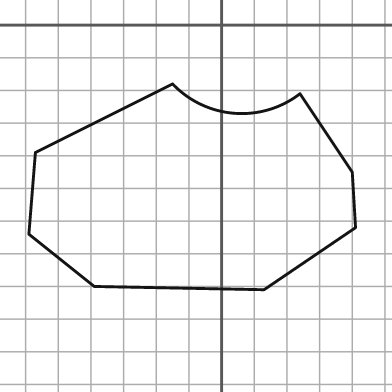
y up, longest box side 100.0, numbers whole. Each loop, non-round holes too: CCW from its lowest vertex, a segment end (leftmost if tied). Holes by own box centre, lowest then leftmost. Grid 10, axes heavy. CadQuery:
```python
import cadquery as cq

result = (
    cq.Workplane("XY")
    .moveTo(13.0, -81.0)
    .lineTo(41.0, -62.0)
    .lineTo(40.0, -45.0)
    .lineTo(24.0, -21.0)
    .threePointArc((4.0, -27.0), (-15.0, -18.0))
    .lineTo(-57.0, -39.0)
    .lineTo(-59.0, -64.0)
    .lineTo(-39.0, -80.0)
    .close()
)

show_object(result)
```